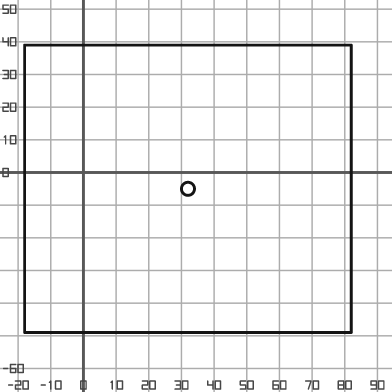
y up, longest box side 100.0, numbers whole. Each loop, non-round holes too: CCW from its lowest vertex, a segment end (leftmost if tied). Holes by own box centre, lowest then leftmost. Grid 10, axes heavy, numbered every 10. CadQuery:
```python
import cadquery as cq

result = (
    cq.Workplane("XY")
    .moveTo(-18.0, -49.0)
    .lineTo(82.0, -49.0)
    .lineTo(82.0, 39.0)
    .lineTo(-18.0, 39.0)
    .close()
    .moveTo(32.0, -5.0)
    .circle(2.0)
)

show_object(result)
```